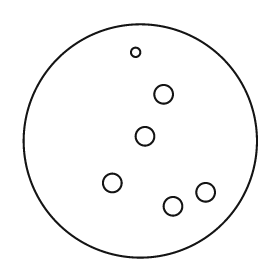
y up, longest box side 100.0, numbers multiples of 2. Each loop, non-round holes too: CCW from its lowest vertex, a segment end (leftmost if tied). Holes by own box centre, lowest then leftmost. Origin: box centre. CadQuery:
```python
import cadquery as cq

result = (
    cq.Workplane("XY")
    .moveTo(0.0, 0.0)
    .circle(50.0)
    .moveTo(14.0, -28.0)
    .circle(4.0)
    .moveTo(28.0, -22.0)
    .circle(4.0)
    .moveTo(-12.0, -18.0)
    .circle(4.0)
    .moveTo(2.0, 2.0)
    .circle(4.0)
    .moveTo(10.0, 20.0)
    .circle(4.0)
    .moveTo(-2.0, 38.0)
    .circle(2.0)
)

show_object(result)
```